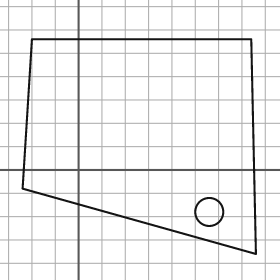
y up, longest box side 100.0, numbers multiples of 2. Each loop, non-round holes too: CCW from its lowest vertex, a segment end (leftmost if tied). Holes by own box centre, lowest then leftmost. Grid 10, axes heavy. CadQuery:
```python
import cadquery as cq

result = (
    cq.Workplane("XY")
    .moveTo(76.0, -36.0)
    .lineTo(74.0, 56.0)
    .lineTo(-20.0, 56.0)
    .lineTo(-24.0, -8.0)
    .close()
    .moveTo(56.0, -18.0)
    .circle(6.0)
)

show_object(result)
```